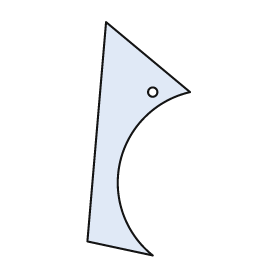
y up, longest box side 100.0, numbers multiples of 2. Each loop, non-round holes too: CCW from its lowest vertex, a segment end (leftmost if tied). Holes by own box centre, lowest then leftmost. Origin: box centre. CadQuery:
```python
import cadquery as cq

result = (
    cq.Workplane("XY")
    .moveTo(6.0, -50.0)
    .threePointArc((-8.0, -10.0), (22.0, 20.0))
    .lineTo(-14.0, 50.0)
    .lineTo(-22.0, -44.0)
    .close()
    .moveTo(6.0, 20.0)
    .circle(2.0)
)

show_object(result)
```